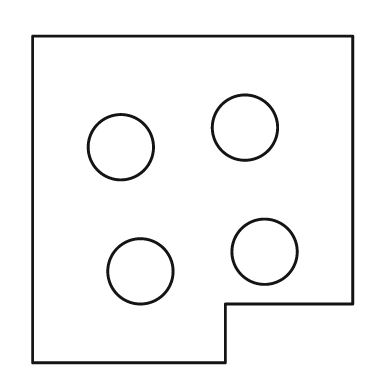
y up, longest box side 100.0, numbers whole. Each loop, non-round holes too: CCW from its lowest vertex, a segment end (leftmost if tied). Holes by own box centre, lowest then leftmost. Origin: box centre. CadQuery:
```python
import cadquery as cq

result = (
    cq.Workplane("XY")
    .moveTo(-49.0, -50.0)
    .lineTo(10.0, -50.0)
    .lineTo(10.0, -32.0)
    .lineTo(49.0, -32.0)
    .lineTo(49.0, 50.0)
    .lineTo(-49.0, 50.0)
    .close()
    .moveTo(-16.0, -22.0)
    .circle(10.0)
    .moveTo(22.0, -16.0)
    .circle(10.0)
    .moveTo(-22.0, 16.0)
    .circle(10.0)
    .moveTo(16.0, 22.0)
    .circle(10.0)
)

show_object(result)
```